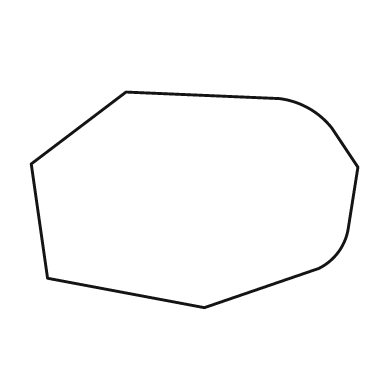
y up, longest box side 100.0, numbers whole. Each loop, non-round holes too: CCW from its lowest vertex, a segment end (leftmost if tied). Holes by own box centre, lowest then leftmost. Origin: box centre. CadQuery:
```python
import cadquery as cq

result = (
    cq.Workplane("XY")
    .moveTo(3.0, -33.0)
    .lineTo(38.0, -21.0)
    .threePointArc((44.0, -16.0), (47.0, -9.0))
    .lineTo(50.0, 10.0)
    .lineTo(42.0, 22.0)
    .threePointArc((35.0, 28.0), (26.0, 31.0))
    .lineTo(-21.0, 33.0)
    .lineTo(-50.0, 11.0)
    .lineTo(-45.0, -24.0)
    .close()
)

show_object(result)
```